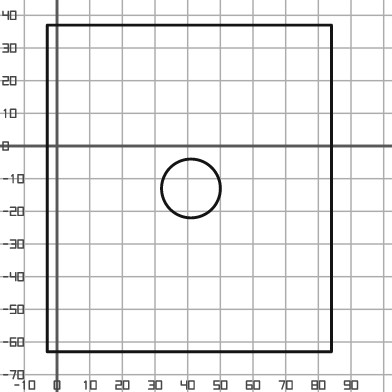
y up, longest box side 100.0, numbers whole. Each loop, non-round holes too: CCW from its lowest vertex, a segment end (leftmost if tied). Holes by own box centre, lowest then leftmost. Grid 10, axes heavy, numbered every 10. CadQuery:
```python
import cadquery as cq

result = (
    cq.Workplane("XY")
    .moveTo(-3.0, -63.0)
    .lineTo(84.0, -63.0)
    .lineTo(84.0, 37.0)
    .lineTo(-3.0, 37.0)
    .close()
    .moveTo(41.0, -13.0)
    .circle(9.0)
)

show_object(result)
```